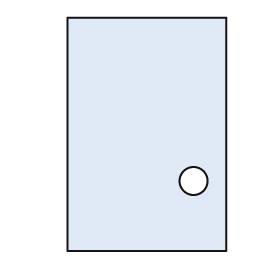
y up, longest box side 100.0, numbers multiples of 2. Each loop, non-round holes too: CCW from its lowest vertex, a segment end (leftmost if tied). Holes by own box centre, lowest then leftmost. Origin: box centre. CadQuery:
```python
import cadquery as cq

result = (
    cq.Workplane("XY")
    .moveTo(-34.0, -50.0)
    .lineTo(34.0, -50.0)
    .lineTo(34.0, 50.0)
    .lineTo(-34.0, 50.0)
    .close()
    .moveTo(20.0, -20.0)
    .circle(6.0)
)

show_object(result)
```